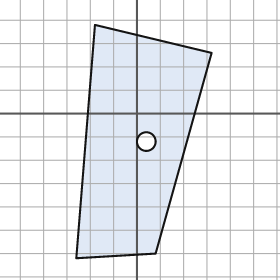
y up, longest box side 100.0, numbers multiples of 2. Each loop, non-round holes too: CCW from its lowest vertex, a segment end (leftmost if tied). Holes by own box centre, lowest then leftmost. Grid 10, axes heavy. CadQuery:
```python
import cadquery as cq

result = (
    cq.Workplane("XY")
    .moveTo(-26.0, -62.0)
    .lineTo(8.0, -60.0)
    .lineTo(32.0, 26.0)
    .lineTo(-18.0, 38.0)
    .close()
    .moveTo(4.0, -12.0)
    .circle(4.0)
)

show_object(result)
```